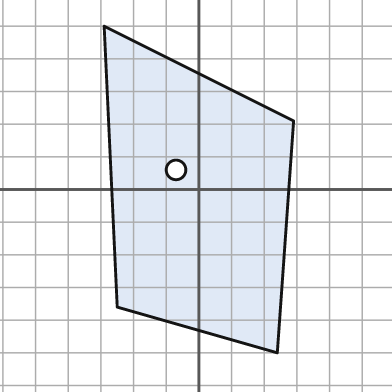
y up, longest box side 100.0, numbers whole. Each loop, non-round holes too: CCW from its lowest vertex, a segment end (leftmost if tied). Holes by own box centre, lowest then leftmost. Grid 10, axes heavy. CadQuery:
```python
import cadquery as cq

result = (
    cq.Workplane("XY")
    .moveTo(24.0, -50.0)
    .lineTo(29.0, 21.0)
    .lineTo(-29.0, 50.0)
    .lineTo(-25.0, -36.0)
    .close()
    .moveTo(-7.0, 6.0)
    .circle(3.0)
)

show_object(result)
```